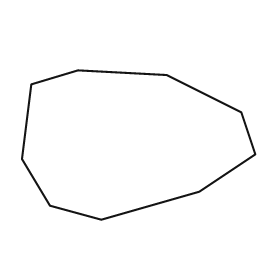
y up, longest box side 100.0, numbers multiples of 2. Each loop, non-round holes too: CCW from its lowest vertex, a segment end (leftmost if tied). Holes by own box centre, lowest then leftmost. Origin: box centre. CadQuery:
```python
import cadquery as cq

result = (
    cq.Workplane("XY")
    .moveTo(-16.0, -32.0)
    .lineTo(26.0, -20.0)
    .lineTo(50.0, -4.0)
    .lineTo(44.0, 14.0)
    .lineTo(12.0, 30.0)
    .lineTo(-26.0, 32.0)
    .lineTo(-46.0, 26.0)
    .lineTo(-50.0, -6.0)
    .lineTo(-38.0, -26.0)
    .close()
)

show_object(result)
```